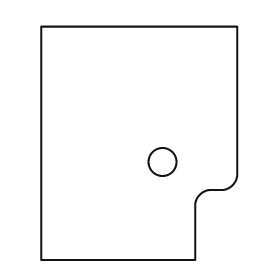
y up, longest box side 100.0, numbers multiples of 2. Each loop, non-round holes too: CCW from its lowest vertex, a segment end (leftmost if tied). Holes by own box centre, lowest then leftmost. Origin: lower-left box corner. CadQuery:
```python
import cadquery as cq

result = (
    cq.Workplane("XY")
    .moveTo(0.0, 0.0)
    .lineTo(66.0, 0.0)
    .lineTo(66.0, 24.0)
    .threePointArc((68.0, 28.0), (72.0, 30.0))
    .lineTo(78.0, 30.0)
    .threePointArc((82.0, 32.0), (84.0, 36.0))
    .lineTo(84.0, 100.0)
    .lineTo(0.0, 100.0)
    .close()
    .moveTo(52.0, 42.0)
    .circle(6.0)
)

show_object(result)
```